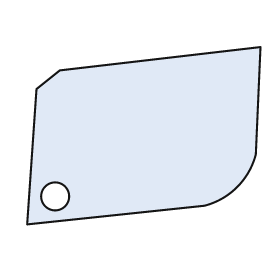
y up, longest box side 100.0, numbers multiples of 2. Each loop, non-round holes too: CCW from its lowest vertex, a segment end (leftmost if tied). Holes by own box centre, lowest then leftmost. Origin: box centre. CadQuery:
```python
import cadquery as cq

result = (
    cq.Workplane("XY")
    .moveTo(-50.0, -38.0)
    .lineTo(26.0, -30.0)
    .threePointArc((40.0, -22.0), (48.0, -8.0))
    .lineTo(50.0, 38.0)
    .lineTo(-36.0, 28.0)
    .lineTo(-46.0, 20.0)
    .close()
    .moveTo(-38.0, -26.0)
    .circle(6.0)
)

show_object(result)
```